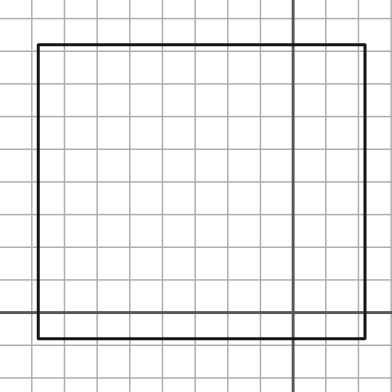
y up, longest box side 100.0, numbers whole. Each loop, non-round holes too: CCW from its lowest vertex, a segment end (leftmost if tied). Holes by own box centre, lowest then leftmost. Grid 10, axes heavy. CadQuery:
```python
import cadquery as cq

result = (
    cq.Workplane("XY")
    .moveTo(-78.0, -8.0)
    .lineTo(22.0, -8.0)
    .lineTo(22.0, 82.0)
    .lineTo(-78.0, 82.0)
    .close()
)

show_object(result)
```